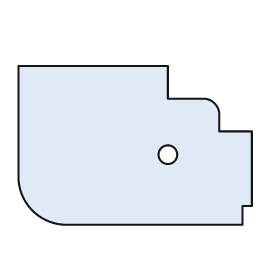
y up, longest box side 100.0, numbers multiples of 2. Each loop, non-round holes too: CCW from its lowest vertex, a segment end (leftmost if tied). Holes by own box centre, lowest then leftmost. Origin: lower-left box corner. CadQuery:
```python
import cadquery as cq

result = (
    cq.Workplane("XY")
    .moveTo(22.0, 0.0)
    .lineTo(96.0, 0.0)
    .lineTo(96.0, 8.0)
    .lineTo(100.0, 8.0)
    .lineTo(100.0, 40.0)
    .lineTo(86.0, 40.0)
    .lineTo(86.0, 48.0)
    .threePointArc((84.0, 52.0), (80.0, 54.0))
    .lineTo(64.0, 54.0)
    .lineTo(64.0, 68.0)
    .lineTo(0.0, 68.0)
    .lineTo(0.0, 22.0)
    .threePointArc((6.0, 6.0), (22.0, 0.0))
    .close()
    .moveTo(64.0, 30.0)
    .circle(4.0)
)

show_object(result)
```